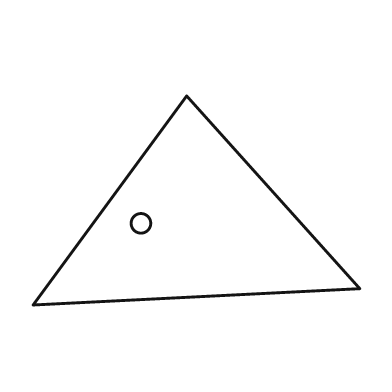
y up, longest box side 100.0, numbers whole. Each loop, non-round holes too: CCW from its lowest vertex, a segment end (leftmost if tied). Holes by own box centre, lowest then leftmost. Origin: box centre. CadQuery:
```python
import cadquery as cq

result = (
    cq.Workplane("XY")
    .moveTo(-50.0, -32.0)
    .lineTo(50.0, -27.0)
    .lineTo(-3.0, 32.0)
    .close()
    .moveTo(-17.0, -7.0)
    .circle(3.0)
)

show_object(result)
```